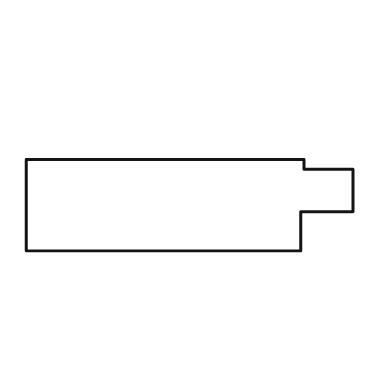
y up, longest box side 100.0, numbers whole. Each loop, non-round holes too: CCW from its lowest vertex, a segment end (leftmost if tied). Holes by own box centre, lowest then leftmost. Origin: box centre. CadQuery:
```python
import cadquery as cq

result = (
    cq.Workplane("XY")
    .moveTo(-50.0, -14.0)
    .lineTo(34.0, -14.0)
    .lineTo(34.0, -2.0)
    .lineTo(50.0, -2.0)
    .lineTo(50.0, 11.0)
    .lineTo(35.0, 11.0)
    .lineTo(35.0, 14.0)
    .lineTo(-50.0, 14.0)
    .close()
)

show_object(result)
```